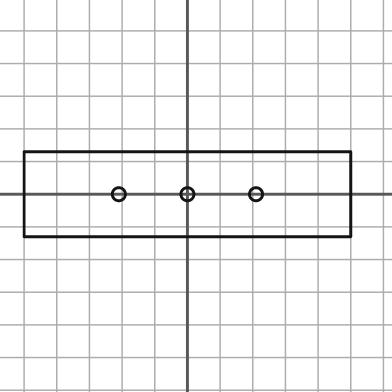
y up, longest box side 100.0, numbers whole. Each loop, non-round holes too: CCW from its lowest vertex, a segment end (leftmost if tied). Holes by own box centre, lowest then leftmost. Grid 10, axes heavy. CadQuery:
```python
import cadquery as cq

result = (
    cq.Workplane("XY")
    .moveTo(-50.0, -13.0)
    .lineTo(50.0, -13.0)
    .lineTo(50.0, 13.0)
    .lineTo(-50.0, 13.0)
    .close()
    .moveTo(-21.0, 0.0)
    .circle(2.0)
    .moveTo(0.0, 0.0)
    .circle(2.0)
    .moveTo(21.0, 0.0)
    .circle(2.0)
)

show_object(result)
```